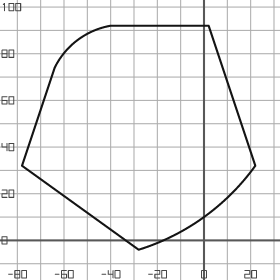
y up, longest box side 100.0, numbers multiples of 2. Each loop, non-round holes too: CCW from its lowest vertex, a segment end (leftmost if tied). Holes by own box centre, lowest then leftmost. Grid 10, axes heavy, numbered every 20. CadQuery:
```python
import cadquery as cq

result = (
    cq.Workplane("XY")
    .moveTo(-28.0, -4.0)
    .threePointArc((0.0, 10.0), (22.0, 32.0))
    .lineTo(2.0, 92.0)
    .lineTo(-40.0, 92.0)
    .threePointArc((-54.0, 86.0), (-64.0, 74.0))
    .lineTo(-78.0, 32.0)
    .close()
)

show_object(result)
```